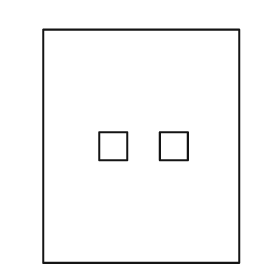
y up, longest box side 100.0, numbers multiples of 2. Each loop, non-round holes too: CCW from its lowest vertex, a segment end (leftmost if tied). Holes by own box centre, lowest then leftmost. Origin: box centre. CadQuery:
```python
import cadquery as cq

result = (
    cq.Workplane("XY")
    .moveTo(-42.0, -50.0)
    .lineTo(42.0, -50.0)
    .lineTo(42.0, 50.0)
    .lineTo(-42.0, 50.0)
    .close()
    .moveTo(-18.0, -6.0)
    .lineTo(-6.0, -6.0)
    .lineTo(-6.0, 6.0)
    .lineTo(-18.0, 6.0)
    .close()
    .moveTo(8.0, -6.0)
    .lineTo(20.0, -6.0)
    .lineTo(20.0, 6.0)
    .lineTo(8.0, 6.0)
    .close()
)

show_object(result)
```